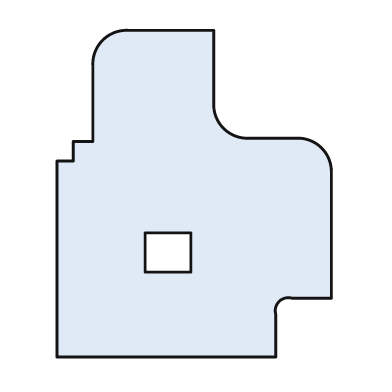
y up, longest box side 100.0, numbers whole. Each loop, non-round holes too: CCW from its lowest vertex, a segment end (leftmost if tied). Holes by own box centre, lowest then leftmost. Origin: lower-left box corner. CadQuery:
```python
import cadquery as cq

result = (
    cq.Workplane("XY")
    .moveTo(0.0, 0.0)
    .lineTo(67.0, 0.0)
    .lineTo(67.0, 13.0)
    .threePointArc((68.0, 17.0), (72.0, 18.0))
    .lineTo(84.0, 18.0)
    .lineTo(84.0, 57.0)
    .threePointArc((81.0, 64.0), (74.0, 67.0))
    .lineTo(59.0, 67.0)
    .threePointArc((51.0, 70.0), (48.0, 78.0))
    .lineTo(48.0, 100.0)
    .lineTo(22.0, 100.0)
    .threePointArc((14.0, 97.0), (11.0, 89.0))
    .lineTo(11.0, 66.0)
    .lineTo(5.0, 66.0)
    .lineTo(5.0, 60.0)
    .lineTo(0.0, 60.0)
    .close()
    .moveTo(27.0, 26.0)
    .lineTo(41.0, 26.0)
    .lineTo(41.0, 38.0)
    .lineTo(27.0, 38.0)
    .close()
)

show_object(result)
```